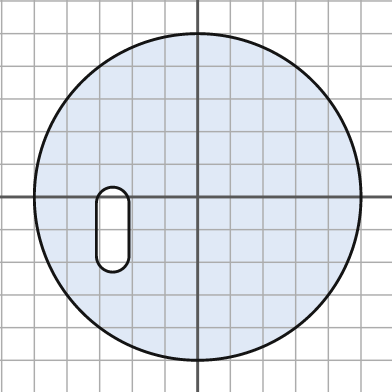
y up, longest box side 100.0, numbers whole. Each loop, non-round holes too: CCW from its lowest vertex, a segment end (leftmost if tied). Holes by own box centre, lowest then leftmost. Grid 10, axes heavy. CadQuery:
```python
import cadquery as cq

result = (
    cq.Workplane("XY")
    .moveTo(0.0, 0.0)
    .circle(50.0)
    .moveTo(-31.0, -18.0)
    .threePointArc((-26.0, -23.0), (-21.0, -18.0))
    .lineTo(-21.0, -2.0)
    .threePointArc((-26.0, 3.0), (-31.0, -2.0))
    .close()
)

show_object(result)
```